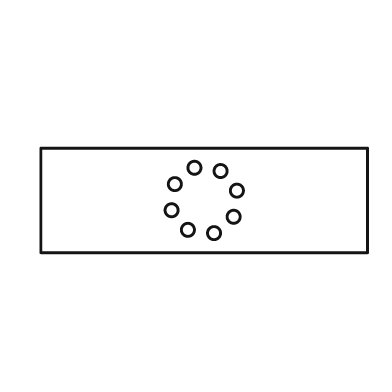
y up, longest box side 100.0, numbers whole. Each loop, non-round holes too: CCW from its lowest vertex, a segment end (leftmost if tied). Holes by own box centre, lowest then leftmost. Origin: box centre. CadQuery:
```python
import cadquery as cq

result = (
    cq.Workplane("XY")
    .moveTo(-50.0, -16.0)
    .lineTo(50.0, -16.0)
    .lineTo(50.0, 16.0)
    .lineTo(-50.0, 16.0)
    .close()
    .moveTo(3.0, -10.0)
    .circle(2.0)
    .moveTo(-5.0, -9.0)
    .circle(2.0)
    .moveTo(9.0, -5.0)
    .circle(2.0)
    .moveTo(-10.0, -3.0)
    .circle(2.0)
    .moveTo(10.0, 3.0)
    .circle(2.0)
    .moveTo(-9.0, 5.0)
    .circle(2.0)
    .moveTo(5.0, 9.0)
    .circle(2.0)
    .moveTo(-3.0, 10.0)
    .circle(2.0)
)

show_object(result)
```